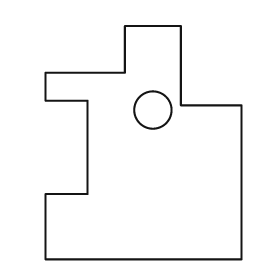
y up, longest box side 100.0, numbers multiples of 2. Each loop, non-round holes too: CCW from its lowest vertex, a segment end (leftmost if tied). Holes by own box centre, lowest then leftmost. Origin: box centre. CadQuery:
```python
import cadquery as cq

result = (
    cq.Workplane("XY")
    .moveTo(-42.0, -50.0)
    .lineTo(42.0, -50.0)
    .lineTo(42.0, 16.0)
    .lineTo(16.0, 16.0)
    .lineTo(16.0, 50.0)
    .lineTo(-8.0, 50.0)
    .lineTo(-8.0, 30.0)
    .lineTo(-42.0, 30.0)
    .lineTo(-42.0, 18.0)
    .lineTo(-24.0, 18.0)
    .lineTo(-24.0, -22.0)
    .lineTo(-42.0, -22.0)
    .close()
    .moveTo(4.0, 14.0)
    .circle(8.0)
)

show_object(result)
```